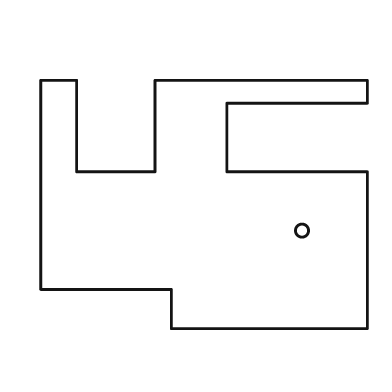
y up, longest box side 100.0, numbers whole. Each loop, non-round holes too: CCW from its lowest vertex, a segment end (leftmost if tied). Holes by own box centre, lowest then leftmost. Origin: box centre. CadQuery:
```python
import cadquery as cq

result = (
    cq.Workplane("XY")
    .moveTo(-10.0, -38.0)
    .lineTo(50.0, -38.0)
    .lineTo(50.0, 10.0)
    .lineTo(7.0, 10.0)
    .lineTo(7.0, 31.0)
    .lineTo(50.0, 31.0)
    .lineTo(50.0, 38.0)
    .lineTo(-15.0, 38.0)
    .lineTo(-15.0, 10.0)
    .lineTo(-39.0, 10.0)
    .lineTo(-39.0, 38.0)
    .lineTo(-50.0, 38.0)
    .lineTo(-50.0, -26.0)
    .lineTo(-10.0, -26.0)
    .close()
    .moveTo(30.0, -8.0)
    .circle(2.0)
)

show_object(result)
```